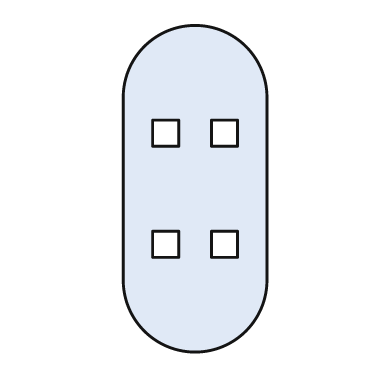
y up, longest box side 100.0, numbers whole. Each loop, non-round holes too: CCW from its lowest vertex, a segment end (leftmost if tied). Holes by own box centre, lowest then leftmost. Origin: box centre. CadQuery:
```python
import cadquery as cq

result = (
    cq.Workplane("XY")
    .moveTo(-22.0, -28.0)
    .threePointArc((0.0, -50.0), (22.0, -28.0))
    .lineTo(22.0, 28.0)
    .threePointArc((0.0, 50.0), (-22.0, 28.0))
    .close()
    .moveTo(-13.0, -21.0)
    .lineTo(-5.0, -21.0)
    .lineTo(-5.0, -13.0)
    .lineTo(-13.0, -13.0)
    .close()
    .moveTo(5.0, -21.0)
    .lineTo(13.0, -21.0)
    .lineTo(13.0, -13.0)
    .lineTo(5.0, -13.0)
    .close()
    .moveTo(-13.0, 13.0)
    .lineTo(-5.0, 13.0)
    .lineTo(-5.0, 21.0)
    .lineTo(-13.0, 21.0)
    .close()
    .moveTo(5.0, 13.0)
    .lineTo(13.0, 13.0)
    .lineTo(13.0, 21.0)
    .lineTo(5.0, 21.0)
    .close()
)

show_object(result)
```